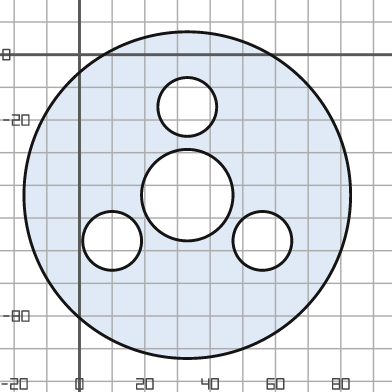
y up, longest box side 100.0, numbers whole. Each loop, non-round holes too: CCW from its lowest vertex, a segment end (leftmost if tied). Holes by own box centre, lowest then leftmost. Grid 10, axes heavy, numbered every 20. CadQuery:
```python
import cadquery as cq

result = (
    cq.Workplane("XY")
    .moveTo(33.0, -43.0)
    .circle(50.0)
    .moveTo(10.0, -57.0)
    .circle(9.0)
    .moveTo(56.0, -57.0)
    .circle(9.0)
    .moveTo(33.0, -43.0)
    .circle(14.0)
    .moveTo(33.0, -16.0)
    .circle(9.0)
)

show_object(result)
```